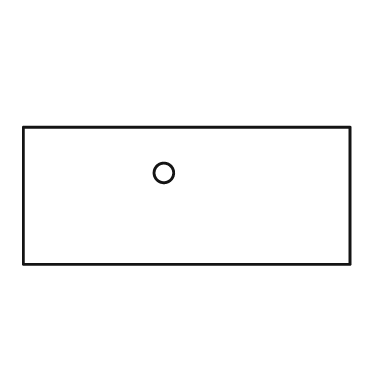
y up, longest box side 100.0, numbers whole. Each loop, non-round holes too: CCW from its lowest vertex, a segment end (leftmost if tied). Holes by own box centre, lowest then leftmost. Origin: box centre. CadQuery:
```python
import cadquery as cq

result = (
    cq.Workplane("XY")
    .moveTo(-50.0, -21.0)
    .lineTo(50.0, -21.0)
    .lineTo(50.0, 21.0)
    .lineTo(-50.0, 21.0)
    .close()
    .moveTo(-7.0, 7.0)
    .circle(3.0)
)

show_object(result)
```